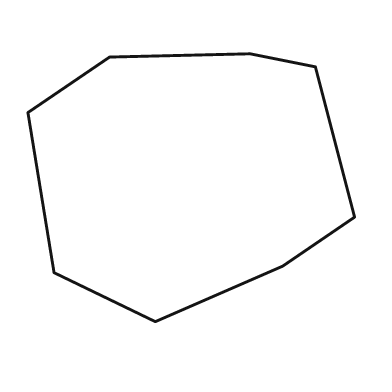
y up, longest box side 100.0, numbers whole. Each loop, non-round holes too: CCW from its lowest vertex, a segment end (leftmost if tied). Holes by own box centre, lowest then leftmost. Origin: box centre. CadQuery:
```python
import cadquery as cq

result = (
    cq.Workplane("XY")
    .moveTo(-11.0, -41.0)
    .lineTo(28.0, -24.0)
    .lineTo(50.0, -9.0)
    .lineTo(38.0, 37.0)
    .lineTo(18.0, 41.0)
    .lineTo(-25.0, 40.0)
    .lineTo(-50.0, 23.0)
    .lineTo(-42.0, -26.0)
    .close()
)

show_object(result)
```